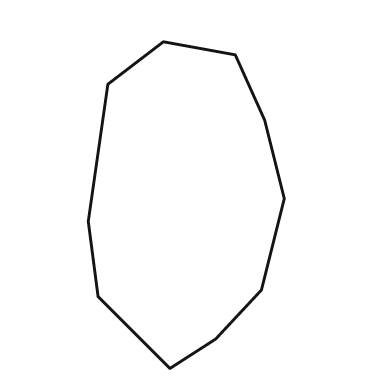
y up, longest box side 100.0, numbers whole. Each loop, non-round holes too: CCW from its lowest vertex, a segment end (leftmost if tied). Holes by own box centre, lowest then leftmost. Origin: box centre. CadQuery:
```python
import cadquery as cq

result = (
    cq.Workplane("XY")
    .moveTo(-5.0, -50.0)
    .lineTo(9.0, -41.0)
    .lineTo(23.0, -26.0)
    .lineTo(30.0, 2.0)
    .lineTo(24.0, 26.0)
    .lineTo(15.0, 46.0)
    .lineTo(-7.0, 50.0)
    .lineTo(-24.0, 37.0)
    .lineTo(-30.0, -5.0)
    .lineTo(-27.0, -28.0)
    .close()
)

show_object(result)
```